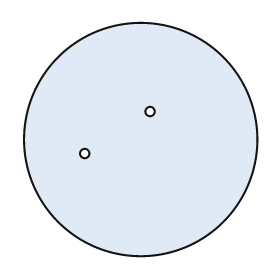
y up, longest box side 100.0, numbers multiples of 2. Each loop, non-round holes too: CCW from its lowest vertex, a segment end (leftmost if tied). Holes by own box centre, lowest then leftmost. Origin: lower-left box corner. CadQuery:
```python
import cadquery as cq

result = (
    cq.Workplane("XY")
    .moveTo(50.0, 50.0)
    .circle(50.0)
    .moveTo(26.0, 44.0)
    .circle(2.0)
    .moveTo(54.0, 62.0)
    .circle(2.0)
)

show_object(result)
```